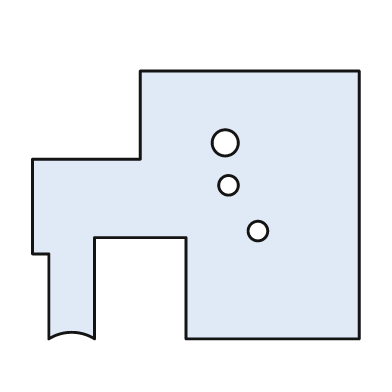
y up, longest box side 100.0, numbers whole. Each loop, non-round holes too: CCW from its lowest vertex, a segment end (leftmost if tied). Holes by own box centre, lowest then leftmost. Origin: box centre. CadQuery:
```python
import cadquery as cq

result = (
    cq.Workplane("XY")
    .moveTo(-45.0, -41.0)
    .threePointArc((-38.0, -39.0), (-31.0, -41.0))
    .lineTo(-31.0, -10.0)
    .lineTo(-3.0, -10.0)
    .lineTo(-3.0, -41.0)
    .lineTo(50.0, -41.0)
    .lineTo(50.0, 41.0)
    .lineTo(-17.0, 41.0)
    .lineTo(-17.0, 14.0)
    .lineTo(-50.0, 14.0)
    .lineTo(-50.0, -15.0)
    .lineTo(-45.0, -15.0)
    .close()
    .moveTo(19.0, -8.0)
    .circle(3.0)
    .moveTo(10.0, 6.0)
    .circle(3.0)
    .moveTo(9.0, 19.0)
    .circle(4.0)
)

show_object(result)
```